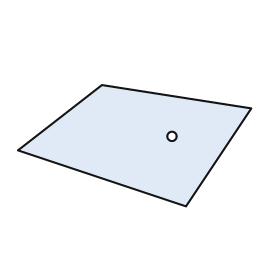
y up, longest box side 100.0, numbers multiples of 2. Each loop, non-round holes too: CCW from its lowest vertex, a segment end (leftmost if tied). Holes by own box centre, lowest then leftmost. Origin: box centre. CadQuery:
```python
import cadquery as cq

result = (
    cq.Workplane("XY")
    .moveTo(22.0, -26.0)
    .lineTo(50.0, 16.0)
    .lineTo(-14.0, 26.0)
    .lineTo(-50.0, -2.0)
    .close()
    .moveTo(16.0, 4.0)
    .circle(2.0)
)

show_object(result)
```